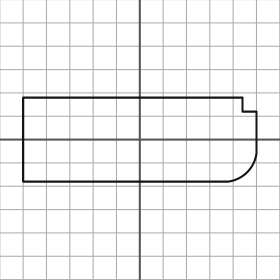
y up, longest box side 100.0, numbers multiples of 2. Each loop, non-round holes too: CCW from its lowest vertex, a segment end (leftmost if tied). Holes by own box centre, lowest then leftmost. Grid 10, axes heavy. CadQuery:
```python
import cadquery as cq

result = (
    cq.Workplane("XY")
    .moveTo(-50.0, -18.0)
    .lineTo(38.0, -18.0)
    .threePointArc((46.0, -14.0), (50.0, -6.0))
    .lineTo(50.0, 12.0)
    .lineTo(44.0, 12.0)
    .lineTo(44.0, 18.0)
    .lineTo(-50.0, 18.0)
    .close()
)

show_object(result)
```